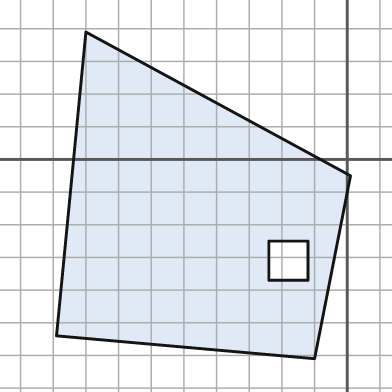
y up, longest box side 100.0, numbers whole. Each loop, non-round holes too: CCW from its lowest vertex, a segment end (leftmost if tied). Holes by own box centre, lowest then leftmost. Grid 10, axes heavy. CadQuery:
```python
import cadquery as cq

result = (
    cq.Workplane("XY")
    .moveTo(-10.0, -61.0)
    .lineTo(1.0, -5.0)
    .lineTo(-80.0, 39.0)
    .lineTo(-89.0, -54.0)
    .close()
    .moveTo(-24.0, -37.0)
    .lineTo(-12.0, -37.0)
    .lineTo(-12.0, -25.0)
    .lineTo(-24.0, -25.0)
    .close()
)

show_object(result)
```